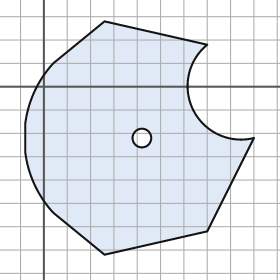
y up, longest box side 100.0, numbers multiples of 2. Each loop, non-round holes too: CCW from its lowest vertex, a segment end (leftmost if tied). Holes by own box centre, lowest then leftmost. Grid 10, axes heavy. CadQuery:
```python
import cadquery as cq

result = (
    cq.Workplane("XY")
    .moveTo(26.0, -72.0)
    .lineTo(70.0, -62.0)
    .lineTo(90.0, -22.0)
    .threePointArc((64.0, -10.0), (70.0, 18.0))
    .lineTo(26.0, 28.0)
    .lineTo(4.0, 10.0)
    .threePointArc((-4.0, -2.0), (-8.0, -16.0))
    .lineTo(-8.0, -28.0)
    .threePointArc((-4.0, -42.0), (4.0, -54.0))
    .close()
    .moveTo(42.0, -22.0)
    .circle(4.0)
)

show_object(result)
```